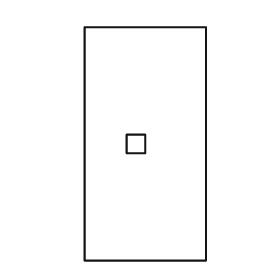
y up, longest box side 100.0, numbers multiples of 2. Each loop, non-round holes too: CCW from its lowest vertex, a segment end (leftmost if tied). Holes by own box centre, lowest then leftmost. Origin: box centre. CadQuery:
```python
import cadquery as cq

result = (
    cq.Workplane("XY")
    .moveTo(-26.0, -50.0)
    .lineTo(26.0, -50.0)
    .lineTo(26.0, 50.0)
    .lineTo(-26.0, 50.0)
    .close()
    .moveTo(-8.0, -4.0)
    .lineTo(0.0, -4.0)
    .lineTo(0.0, 4.0)
    .lineTo(-8.0, 4.0)
    .close()
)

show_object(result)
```